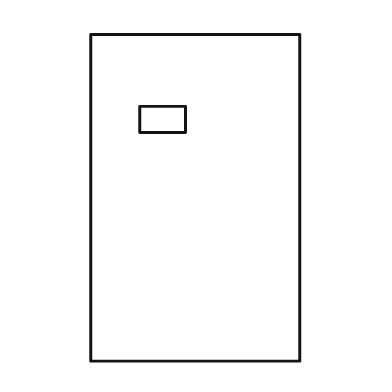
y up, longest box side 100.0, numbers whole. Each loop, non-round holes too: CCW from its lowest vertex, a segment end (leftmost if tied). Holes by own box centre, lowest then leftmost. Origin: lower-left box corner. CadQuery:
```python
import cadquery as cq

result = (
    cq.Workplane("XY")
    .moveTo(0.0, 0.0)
    .lineTo(64.0, 0.0)
    .lineTo(64.0, 100.0)
    .lineTo(0.0, 100.0)
    .close()
    .moveTo(15.0, 70.0)
    .lineTo(29.0, 70.0)
    .lineTo(29.0, 78.0)
    .lineTo(15.0, 78.0)
    .close()
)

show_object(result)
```